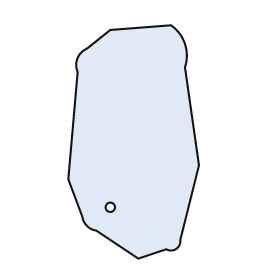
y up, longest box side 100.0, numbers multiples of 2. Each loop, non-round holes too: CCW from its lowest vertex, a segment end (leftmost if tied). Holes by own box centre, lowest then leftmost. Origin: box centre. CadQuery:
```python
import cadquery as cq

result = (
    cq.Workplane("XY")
    .moveTo(2.0, -50.0)
    .lineTo(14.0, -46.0)
    .threePointArc((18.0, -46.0), (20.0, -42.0))
    .lineTo(28.0, -10.0)
    .lineTo(22.0, 32.0)
    .threePointArc((22.0, 42.0), (16.0, 50.0))
    .lineTo(-10.0, 48.0)
    .lineTo(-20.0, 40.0)
    .threePointArc((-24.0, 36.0), (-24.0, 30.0))
    .lineTo(-28.0, -16.0)
    .lineTo(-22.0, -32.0)
    .threePointArc((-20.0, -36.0), (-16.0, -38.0))
    .close()
    .moveTo(-10.0, -28.0)
    .circle(2.0)
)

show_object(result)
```